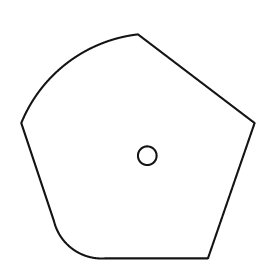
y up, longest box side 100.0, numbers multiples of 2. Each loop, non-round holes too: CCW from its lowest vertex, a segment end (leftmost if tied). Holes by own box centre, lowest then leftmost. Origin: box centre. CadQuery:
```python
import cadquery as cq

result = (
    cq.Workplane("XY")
    .moveTo(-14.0, -48.0)
    .lineTo(30.0, -48.0)
    .lineTo(50.0, 10.0)
    .lineTo(0.0, 48.0)
    .threePointArc((-30.0, 36.0), (-50.0, 10.0))
    .lineTo(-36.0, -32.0)
    .threePointArc((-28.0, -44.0), (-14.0, -48.0))
    .close()
    .moveTo(4.0, -4.0)
    .circle(4.0)
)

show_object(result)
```